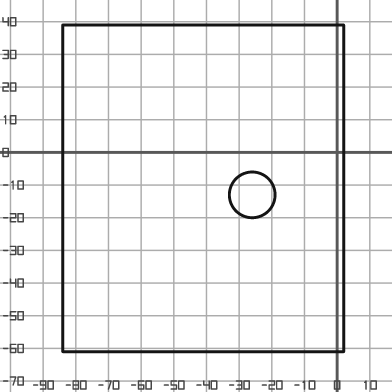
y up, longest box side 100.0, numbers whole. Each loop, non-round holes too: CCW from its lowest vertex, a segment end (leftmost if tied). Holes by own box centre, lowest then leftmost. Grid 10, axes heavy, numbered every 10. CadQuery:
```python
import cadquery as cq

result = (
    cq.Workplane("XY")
    .moveTo(-84.0, -61.0)
    .lineTo(2.0, -61.0)
    .lineTo(2.0, 39.0)
    .lineTo(-84.0, 39.0)
    .close()
    .moveTo(-26.0, -13.0)
    .circle(7.0)
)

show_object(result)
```